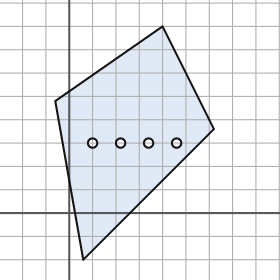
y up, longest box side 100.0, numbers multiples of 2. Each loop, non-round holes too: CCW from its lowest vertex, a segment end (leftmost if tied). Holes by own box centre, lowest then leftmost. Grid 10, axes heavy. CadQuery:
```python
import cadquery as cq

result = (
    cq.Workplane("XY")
    .moveTo(6.0, -20.0)
    .lineTo(62.0, 36.0)
    .lineTo(40.0, 80.0)
    .lineTo(-6.0, 48.0)
    .close()
    .moveTo(10.0, 30.0)
    .circle(2.0)
    .moveTo(22.0, 30.0)
    .circle(2.0)
    .moveTo(34.0, 30.0)
    .circle(2.0)
    .moveTo(46.0, 30.0)
    .circle(2.0)
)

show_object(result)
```